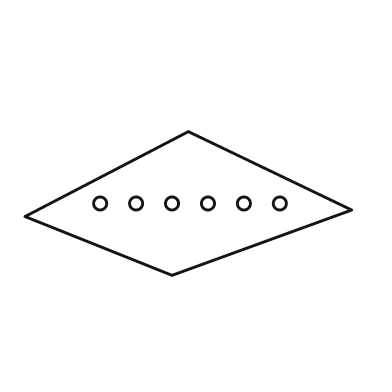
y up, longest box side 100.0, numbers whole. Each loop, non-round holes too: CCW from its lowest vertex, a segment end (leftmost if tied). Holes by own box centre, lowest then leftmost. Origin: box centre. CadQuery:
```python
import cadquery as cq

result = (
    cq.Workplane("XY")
    .moveTo(-5.0, -22.0)
    .lineTo(50.0, -2.0)
    .lineTo(0.0, 22.0)
    .lineTo(-50.0, -4.0)
    .close()
    .moveTo(-27.0, 0.0)
    .circle(2.0)
    .moveTo(-16.0, 0.0)
    .circle(2.0)
    .moveTo(-5.0, 0.0)
    .circle(2.0)
    .moveTo(6.0, 0.0)
    .circle(2.0)
    .moveTo(17.0, 0.0)
    .circle(2.0)
    .moveTo(28.0, 0.0)
    .circle(2.0)
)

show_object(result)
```